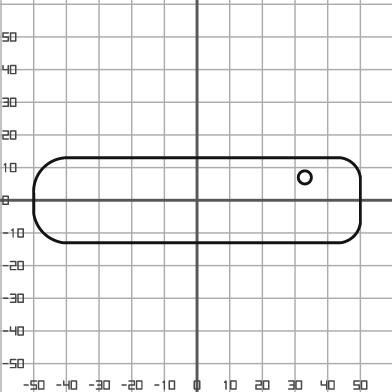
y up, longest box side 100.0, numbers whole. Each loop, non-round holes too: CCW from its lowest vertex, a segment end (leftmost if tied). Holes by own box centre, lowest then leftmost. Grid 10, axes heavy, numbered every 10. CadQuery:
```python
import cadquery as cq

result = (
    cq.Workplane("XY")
    .moveTo(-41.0, -13.0)
    .lineTo(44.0, -13.0)
    .threePointArc((48.0, -11.0), (50.0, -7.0))
    .lineTo(50.0, 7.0)
    .threePointArc((48.0, 11.0), (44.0, 13.0))
    .lineTo(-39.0, 13.0)
    .threePointArc((-47.0, 10.0), (-50.0, 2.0))
    .lineTo(-50.0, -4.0)
    .threePointArc((-47.0, -10.0), (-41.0, -13.0))
    .close()
    .moveTo(33.0, 7.0)
    .circle(2.0)
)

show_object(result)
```